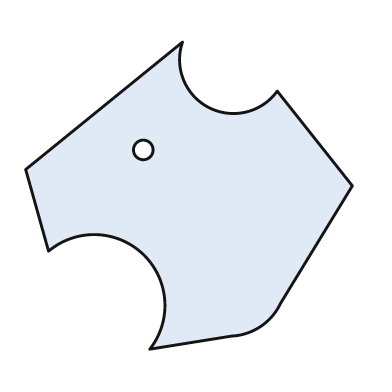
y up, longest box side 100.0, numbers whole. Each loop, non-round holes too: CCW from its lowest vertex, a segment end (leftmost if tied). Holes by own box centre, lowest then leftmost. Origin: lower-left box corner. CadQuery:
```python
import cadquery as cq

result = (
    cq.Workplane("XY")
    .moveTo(38.0, 0.0)
    .lineTo(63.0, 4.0)
    .threePointArc((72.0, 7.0), (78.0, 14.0))
    .lineTo(100.0, 50.0)
    .lineTo(77.0, 79.0)
    .threePointArc((56.0, 74.0), (48.0, 94.0))
    .lineTo(0.0, 55.0)
    .lineTo(7.0, 30.0)
    .threePointArc((36.0, 29.0), (38.0, 0.0))
    .close()
    .moveTo(36.0, 61.0)
    .circle(3.0)
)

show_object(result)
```